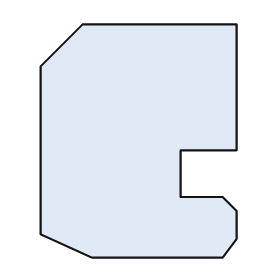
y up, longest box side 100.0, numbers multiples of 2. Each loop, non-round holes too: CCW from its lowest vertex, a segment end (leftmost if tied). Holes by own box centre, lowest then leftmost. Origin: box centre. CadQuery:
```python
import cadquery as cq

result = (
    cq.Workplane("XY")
    .moveTo(-20.0, -50.0)
    .lineTo(36.0, -50.0)
    .lineTo(42.0, -42.0)
    .lineTo(42.0, -30.0)
    .lineTo(36.0, -24.0)
    .lineTo(18.0, -24.0)
    .lineTo(18.0, -4.0)
    .lineTo(42.0, -4.0)
    .lineTo(42.0, 50.0)
    .lineTo(-24.0, 50.0)
    .lineTo(-42.0, 32.0)
    .lineTo(-42.0, -40.0)
    .close()
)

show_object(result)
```